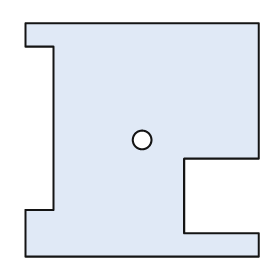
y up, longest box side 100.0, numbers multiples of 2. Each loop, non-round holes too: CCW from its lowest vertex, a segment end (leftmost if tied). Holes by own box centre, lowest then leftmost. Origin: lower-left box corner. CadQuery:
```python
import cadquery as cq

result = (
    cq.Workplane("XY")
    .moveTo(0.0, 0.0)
    .lineTo(100.0, 0.0)
    .lineTo(100.0, 10.0)
    .lineTo(68.0, 10.0)
    .lineTo(68.0, 42.0)
    .lineTo(100.0, 42.0)
    .lineTo(100.0, 100.0)
    .lineTo(0.0, 100.0)
    .lineTo(0.0, 90.0)
    .lineTo(12.0, 90.0)
    .lineTo(12.0, 20.0)
    .lineTo(0.0, 20.0)
    .close()
    .moveTo(50.0, 50.0)
    .circle(4.0)
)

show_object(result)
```